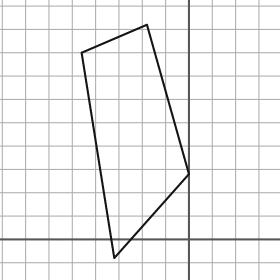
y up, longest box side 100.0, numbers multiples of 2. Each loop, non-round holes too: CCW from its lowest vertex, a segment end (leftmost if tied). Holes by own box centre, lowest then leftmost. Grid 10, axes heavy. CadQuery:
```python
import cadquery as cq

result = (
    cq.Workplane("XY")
    .moveTo(-32.0, -8.0)
    .lineTo(0.0, 28.0)
    .lineTo(-18.0, 92.0)
    .lineTo(-46.0, 80.0)
    .close()
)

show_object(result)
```